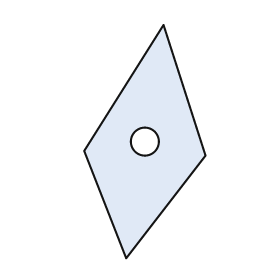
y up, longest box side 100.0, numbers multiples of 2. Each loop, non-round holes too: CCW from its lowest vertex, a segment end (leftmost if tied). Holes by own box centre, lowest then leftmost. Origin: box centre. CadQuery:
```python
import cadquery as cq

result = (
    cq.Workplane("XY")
    .moveTo(-8.0, -50.0)
    .lineTo(26.0, -6.0)
    .lineTo(8.0, 50.0)
    .lineTo(-26.0, -4.0)
    .close()
    .moveTo(0.0, 0.0)
    .circle(6.0)
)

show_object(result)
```